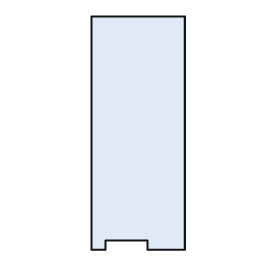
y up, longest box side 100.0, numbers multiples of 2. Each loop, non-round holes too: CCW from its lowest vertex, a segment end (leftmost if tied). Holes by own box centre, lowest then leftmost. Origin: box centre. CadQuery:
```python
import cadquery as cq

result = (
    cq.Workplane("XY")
    .moveTo(-20.0, -50.0)
    .lineTo(-14.0, -50.0)
    .lineTo(-14.0, -46.0)
    .lineTo(4.0, -46.0)
    .lineTo(4.0, -50.0)
    .lineTo(20.0, -50.0)
    .lineTo(20.0, 50.0)
    .lineTo(-20.0, 50.0)
    .close()
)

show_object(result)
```